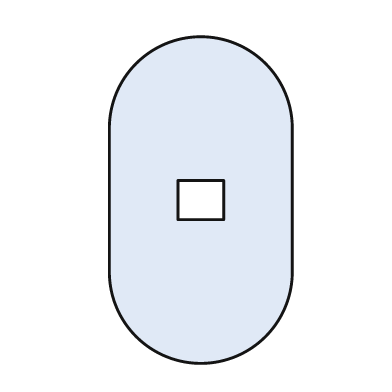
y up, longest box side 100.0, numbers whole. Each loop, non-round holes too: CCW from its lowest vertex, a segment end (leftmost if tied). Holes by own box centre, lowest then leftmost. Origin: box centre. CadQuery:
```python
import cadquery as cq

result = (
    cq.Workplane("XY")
    .moveTo(-28.0, -22.0)
    .threePointArc((0.0, -50.0), (28.0, -22.0))
    .lineTo(28.0, 22.0)
    .threePointArc((0.0, 50.0), (-28.0, 22.0))
    .close()
    .moveTo(-7.0, -6.0)
    .lineTo(7.0, -6.0)
    .lineTo(7.0, 6.0)
    .lineTo(-7.0, 6.0)
    .close()
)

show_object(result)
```